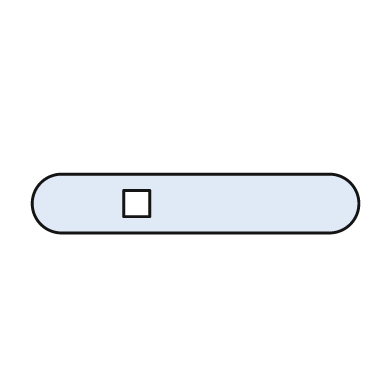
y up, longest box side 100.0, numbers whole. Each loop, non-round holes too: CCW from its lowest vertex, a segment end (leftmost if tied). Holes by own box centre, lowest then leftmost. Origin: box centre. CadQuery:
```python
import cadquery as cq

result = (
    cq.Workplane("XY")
    .moveTo(-41.0, -9.0)
    .lineTo(41.0, -9.0)
    .threePointArc((50.0, 0.0), (41.0, 9.0))
    .lineTo(-41.0, 9.0)
    .threePointArc((-50.0, 0.0), (-41.0, -9.0))
    .close()
    .moveTo(-22.0, -4.0)
    .lineTo(-14.0, -4.0)
    .lineTo(-14.0, 4.0)
    .lineTo(-22.0, 4.0)
    .close()
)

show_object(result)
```